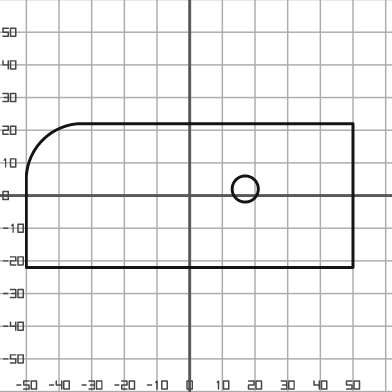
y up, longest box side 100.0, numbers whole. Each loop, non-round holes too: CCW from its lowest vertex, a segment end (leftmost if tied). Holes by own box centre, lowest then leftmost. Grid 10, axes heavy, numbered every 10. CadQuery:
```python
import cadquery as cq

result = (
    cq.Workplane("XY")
    .moveTo(-50.0, -22.0)
    .lineTo(50.0, -22.0)
    .lineTo(50.0, 22.0)
    .lineTo(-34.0, 22.0)
    .threePointArc((-45.0, 17.0), (-50.0, 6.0))
    .close()
    .moveTo(17.0, 2.0)
    .circle(4.0)
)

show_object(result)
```